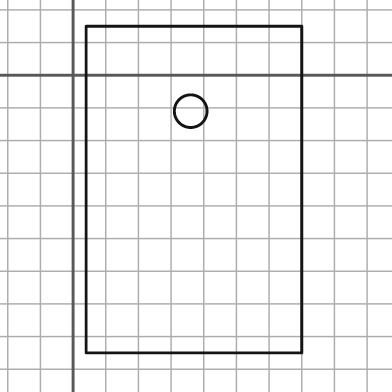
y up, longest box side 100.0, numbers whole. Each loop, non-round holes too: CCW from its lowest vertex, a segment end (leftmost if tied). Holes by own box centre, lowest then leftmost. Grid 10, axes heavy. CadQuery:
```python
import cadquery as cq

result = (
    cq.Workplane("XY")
    .moveTo(4.0, -85.0)
    .lineTo(70.0, -85.0)
    .lineTo(70.0, 15.0)
    .lineTo(4.0, 15.0)
    .close()
    .moveTo(36.0, -11.0)
    .circle(5.0)
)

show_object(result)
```